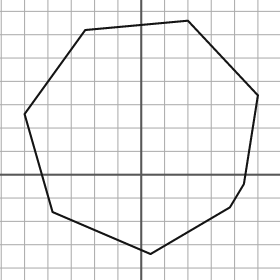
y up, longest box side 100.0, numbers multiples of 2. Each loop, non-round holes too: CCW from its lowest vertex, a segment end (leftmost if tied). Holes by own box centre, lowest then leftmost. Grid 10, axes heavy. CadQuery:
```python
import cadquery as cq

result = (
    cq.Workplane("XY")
    .moveTo(4.0, -34.0)
    .lineTo(38.0, -14.0)
    .lineTo(44.0, -4.0)
    .lineTo(50.0, 34.0)
    .lineTo(20.0, 66.0)
    .lineTo(-24.0, 62.0)
    .lineTo(-50.0, 26.0)
    .lineTo(-38.0, -16.0)
    .close()
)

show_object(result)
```